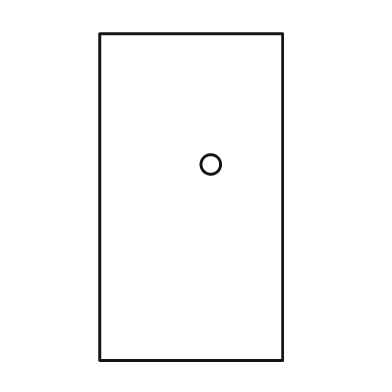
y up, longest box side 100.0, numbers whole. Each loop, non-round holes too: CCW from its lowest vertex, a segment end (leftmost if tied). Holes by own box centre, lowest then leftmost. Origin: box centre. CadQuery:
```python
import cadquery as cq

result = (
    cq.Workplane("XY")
    .moveTo(-28.0, -50.0)
    .lineTo(28.0, -50.0)
    .lineTo(28.0, 50.0)
    .lineTo(-28.0, 50.0)
    .close()
    .moveTo(6.0, 10.0)
    .circle(3.0)
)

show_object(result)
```